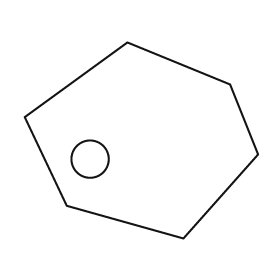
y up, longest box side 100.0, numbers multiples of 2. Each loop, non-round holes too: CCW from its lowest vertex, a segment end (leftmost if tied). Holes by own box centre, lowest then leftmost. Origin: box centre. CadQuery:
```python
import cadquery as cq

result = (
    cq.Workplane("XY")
    .moveTo(18.0, -42.0)
    .lineTo(50.0, -6.0)
    .lineTo(38.0, 24.0)
    .lineTo(-6.0, 42.0)
    .lineTo(-50.0, 10.0)
    .lineTo(-32.0, -28.0)
    .close()
    .moveTo(-22.0, -8.0)
    .circle(8.0)
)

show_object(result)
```